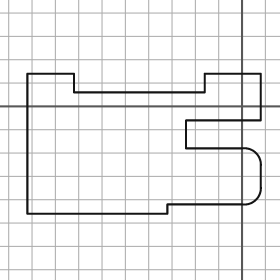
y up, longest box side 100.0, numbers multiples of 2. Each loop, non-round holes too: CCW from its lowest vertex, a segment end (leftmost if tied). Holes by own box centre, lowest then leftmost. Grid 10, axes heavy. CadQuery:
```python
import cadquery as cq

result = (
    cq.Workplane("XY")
    .moveTo(-92.0, -46.0)
    .lineTo(-32.0, -46.0)
    .lineTo(-32.0, -42.0)
    .lineTo(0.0, -42.0)
    .threePointArc((6.0, -40.0), (8.0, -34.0))
    .lineTo(8.0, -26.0)
    .threePointArc((6.0, -20.0), (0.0, -18.0))
    .lineTo(-24.0, -18.0)
    .lineTo(-24.0, -6.0)
    .lineTo(8.0, -6.0)
    .lineTo(8.0, 14.0)
    .lineTo(-16.0, 14.0)
    .lineTo(-16.0, 6.0)
    .lineTo(-72.0, 6.0)
    .lineTo(-72.0, 14.0)
    .lineTo(-92.0, 14.0)
    .close()
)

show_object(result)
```